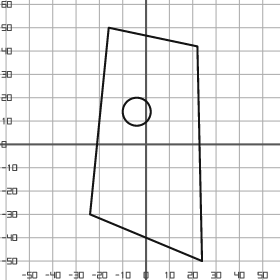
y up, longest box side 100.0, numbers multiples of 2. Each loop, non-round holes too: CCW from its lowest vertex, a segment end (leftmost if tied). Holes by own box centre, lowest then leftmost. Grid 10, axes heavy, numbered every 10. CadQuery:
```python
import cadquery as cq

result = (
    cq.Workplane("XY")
    .moveTo(24.0, -50.0)
    .lineTo(22.0, 42.0)
    .lineTo(-16.0, 50.0)
    .lineTo(-24.0, -30.0)
    .close()
    .moveTo(-4.0, 14.0)
    .circle(6.0)
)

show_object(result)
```